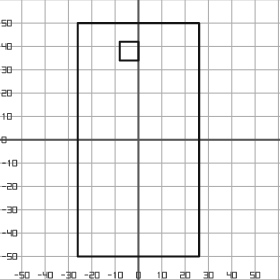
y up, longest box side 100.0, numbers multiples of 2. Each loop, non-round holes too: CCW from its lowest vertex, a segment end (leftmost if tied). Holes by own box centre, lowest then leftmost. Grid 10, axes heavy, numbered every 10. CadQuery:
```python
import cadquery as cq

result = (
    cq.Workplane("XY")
    .moveTo(-26.0, -50.0)
    .lineTo(26.0, -50.0)
    .lineTo(26.0, 50.0)
    .lineTo(-26.0, 50.0)
    .close()
    .moveTo(-8.0, 34.0)
    .lineTo(0.0, 34.0)
    .lineTo(0.0, 42.0)
    .lineTo(-8.0, 42.0)
    .close()
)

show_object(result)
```